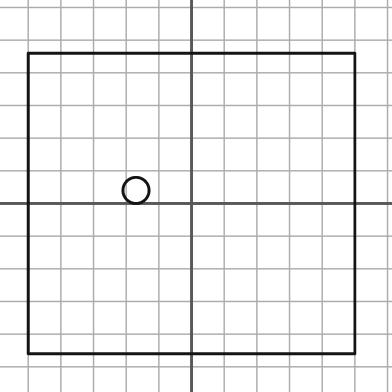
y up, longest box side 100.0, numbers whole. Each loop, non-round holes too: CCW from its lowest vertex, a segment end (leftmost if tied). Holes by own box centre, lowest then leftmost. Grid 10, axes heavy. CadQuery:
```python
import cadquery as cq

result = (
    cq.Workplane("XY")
    .moveTo(-50.0, -46.0)
    .lineTo(50.0, -46.0)
    .lineTo(50.0, 46.0)
    .lineTo(-50.0, 46.0)
    .close()
    .moveTo(-17.0, 4.0)
    .circle(4.0)
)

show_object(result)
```